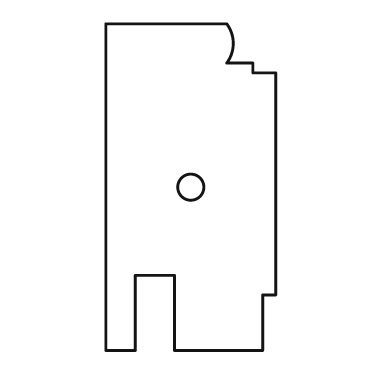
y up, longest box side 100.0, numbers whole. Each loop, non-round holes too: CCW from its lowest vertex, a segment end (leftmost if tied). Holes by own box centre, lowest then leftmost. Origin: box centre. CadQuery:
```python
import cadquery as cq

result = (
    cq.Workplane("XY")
    .moveTo(-26.0, -50.0)
    .lineTo(-17.0, -50.0)
    .lineTo(-17.0, -27.0)
    .lineTo(-5.0, -27.0)
    .lineTo(-5.0, -50.0)
    .lineTo(22.0, -50.0)
    .lineTo(22.0, -33.0)
    .lineTo(26.0, -33.0)
    .lineTo(26.0, 35.0)
    .lineTo(19.0, 35.0)
    .lineTo(19.0, 38.0)
    .lineTo(11.0, 38.0)
    .threePointArc((13.0, 44.0), (11.0, 50.0))
    .lineTo(-26.0, 50.0)
    .close()
    .moveTo(0.0, 0.0)
    .circle(4.0)
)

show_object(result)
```